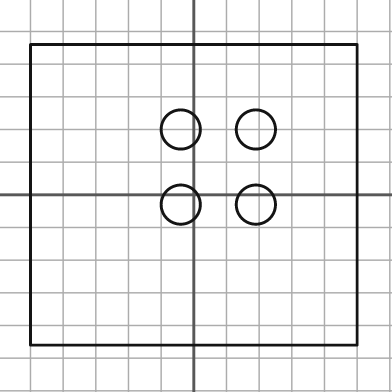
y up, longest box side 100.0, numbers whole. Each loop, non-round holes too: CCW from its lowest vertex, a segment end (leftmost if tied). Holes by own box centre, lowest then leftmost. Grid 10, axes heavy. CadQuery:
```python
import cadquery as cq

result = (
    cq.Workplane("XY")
    .moveTo(-50.0, -46.0)
    .lineTo(50.0, -46.0)
    .lineTo(50.0, 46.0)
    .lineTo(-50.0, 46.0)
    .close()
    .moveTo(-4.0, -3.0)
    .circle(6.0)
    .moveTo(19.0, -3.0)
    .circle(6.0)
    .moveTo(-4.0, 20.0)
    .circle(6.0)
    .moveTo(19.0, 20.0)
    .circle(6.0)
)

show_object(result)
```